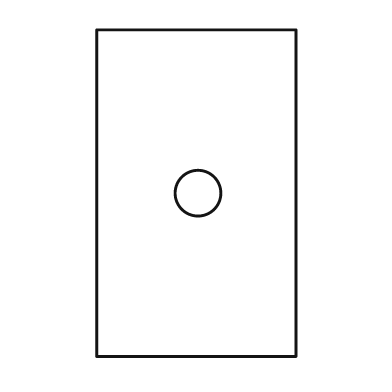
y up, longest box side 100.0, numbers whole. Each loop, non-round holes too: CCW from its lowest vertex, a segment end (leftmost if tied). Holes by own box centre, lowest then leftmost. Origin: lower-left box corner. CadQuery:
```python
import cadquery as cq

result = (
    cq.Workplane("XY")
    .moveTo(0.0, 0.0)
    .lineTo(61.0, 0.0)
    .lineTo(61.0, 100.0)
    .lineTo(0.0, 100.0)
    .close()
    .moveTo(31.0, 50.0)
    .circle(7.0)
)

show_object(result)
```